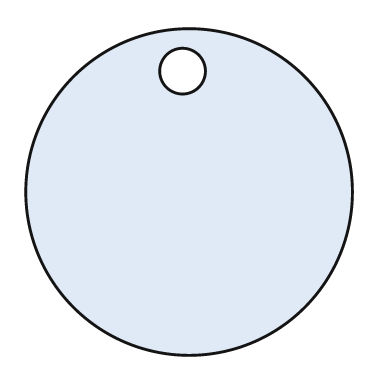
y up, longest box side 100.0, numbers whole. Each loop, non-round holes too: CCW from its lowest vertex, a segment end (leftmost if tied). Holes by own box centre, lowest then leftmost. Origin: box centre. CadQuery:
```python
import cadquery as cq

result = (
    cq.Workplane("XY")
    .moveTo(0.0, 0.0)
    .circle(50.0)
    .moveTo(-2.0, 37.0)
    .circle(7.0)
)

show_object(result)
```